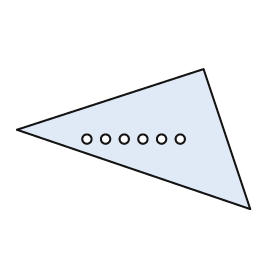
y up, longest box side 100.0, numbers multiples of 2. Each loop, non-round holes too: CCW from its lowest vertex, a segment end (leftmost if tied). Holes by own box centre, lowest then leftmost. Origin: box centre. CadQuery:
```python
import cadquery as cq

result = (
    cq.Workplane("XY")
    .moveTo(50.0, -30.0)
    .lineTo(30.0, 30.0)
    .lineTo(-50.0, 4.0)
    .close()
    .moveTo(-20.0, 0.0)
    .circle(2.0)
    .moveTo(-12.0, 0.0)
    .circle(2.0)
    .moveTo(-4.0, 0.0)
    .circle(2.0)
    .moveTo(4.0, 0.0)
    .circle(2.0)
    .moveTo(12.0, 0.0)
    .circle(2.0)
    .moveTo(20.0, 0.0)
    .circle(2.0)
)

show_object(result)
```